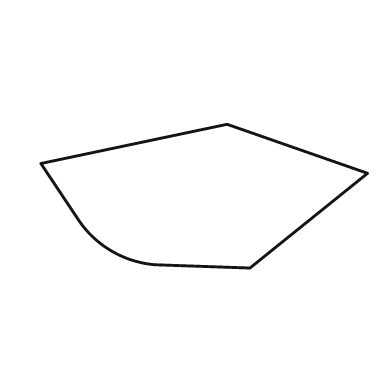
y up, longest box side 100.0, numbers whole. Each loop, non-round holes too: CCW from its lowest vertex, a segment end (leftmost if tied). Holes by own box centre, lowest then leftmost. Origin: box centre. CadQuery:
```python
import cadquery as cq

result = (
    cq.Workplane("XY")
    .moveTo(14.0, -22.0)
    .lineTo(50.0, 7.0)
    .lineTo(7.0, 22.0)
    .lineTo(-50.0, 10.0)
    .lineTo(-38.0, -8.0)
    .threePointArc((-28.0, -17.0), (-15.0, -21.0))
    .close()
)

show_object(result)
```